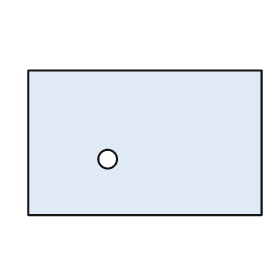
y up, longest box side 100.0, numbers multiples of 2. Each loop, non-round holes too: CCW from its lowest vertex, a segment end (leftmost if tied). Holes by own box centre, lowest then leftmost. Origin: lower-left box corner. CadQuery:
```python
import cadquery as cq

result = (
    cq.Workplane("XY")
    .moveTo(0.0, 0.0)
    .lineTo(100.0, 0.0)
    .lineTo(100.0, 62.0)
    .lineTo(0.0, 62.0)
    .close()
    .moveTo(34.0, 24.0)
    .circle(4.0)
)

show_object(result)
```